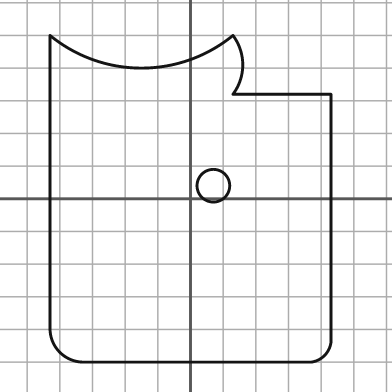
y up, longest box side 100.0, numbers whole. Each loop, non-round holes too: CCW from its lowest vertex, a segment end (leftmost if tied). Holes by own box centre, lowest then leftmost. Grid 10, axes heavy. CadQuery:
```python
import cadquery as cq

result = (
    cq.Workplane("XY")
    .moveTo(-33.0, -50.0)
    .lineTo(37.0, -50.0)
    .threePointArc((41.0, -48.0), (43.0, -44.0))
    .lineTo(43.0, 32.0)
    .lineTo(13.0, 32.0)
    .threePointArc((16.0, 41.0), (13.0, 50.0))
    .threePointArc((-15.0, 40.0), (-43.0, 50.0))
    .lineTo(-43.0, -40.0)
    .threePointArc((-40.0, -47.0), (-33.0, -50.0))
    .close()
    .moveTo(7.0, 4.0)
    .circle(5.0)
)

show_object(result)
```